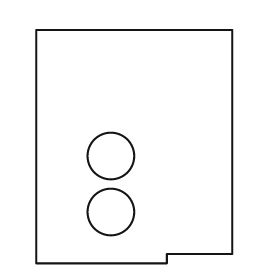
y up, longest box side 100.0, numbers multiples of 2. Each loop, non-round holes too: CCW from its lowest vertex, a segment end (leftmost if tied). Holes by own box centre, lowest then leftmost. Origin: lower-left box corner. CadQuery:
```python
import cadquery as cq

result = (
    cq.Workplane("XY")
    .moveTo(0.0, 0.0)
    .lineTo(56.0, 0.0)
    .lineTo(56.0, 4.0)
    .lineTo(84.0, 4.0)
    .lineTo(84.0, 100.0)
    .lineTo(0.0, 100.0)
    .close()
    .moveTo(32.0, 22.0)
    .circle(10.0)
    .moveTo(32.0, 46.0)
    .circle(10.0)
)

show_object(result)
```